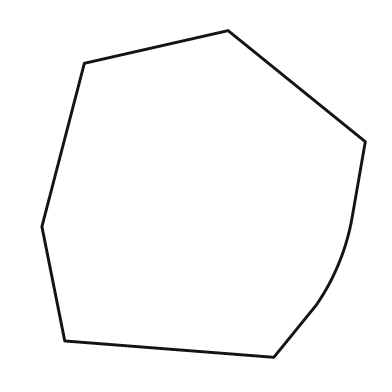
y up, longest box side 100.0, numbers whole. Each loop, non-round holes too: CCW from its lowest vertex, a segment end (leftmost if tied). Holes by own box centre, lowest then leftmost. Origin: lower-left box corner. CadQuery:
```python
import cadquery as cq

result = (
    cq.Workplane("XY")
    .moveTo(71.0, 0.0)
    .lineTo(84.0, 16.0)
    .threePointArc((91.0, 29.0), (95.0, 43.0))
    .lineTo(99.0, 66.0)
    .lineTo(57.0, 100.0)
    .lineTo(13.0, 90.0)
    .lineTo(0.0, 40.0)
    .lineTo(7.0, 5.0)
    .close()
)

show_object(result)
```